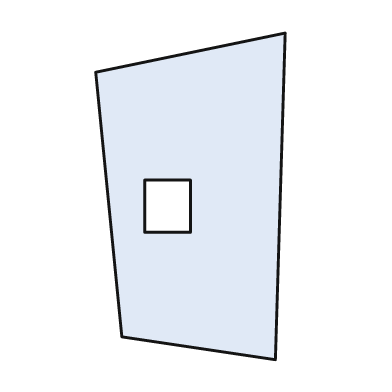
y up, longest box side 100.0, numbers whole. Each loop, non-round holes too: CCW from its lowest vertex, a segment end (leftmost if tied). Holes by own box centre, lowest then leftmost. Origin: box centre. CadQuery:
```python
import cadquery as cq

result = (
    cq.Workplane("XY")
    .moveTo(26.0, -50.0)
    .lineTo(29.0, 50.0)
    .lineTo(-29.0, 38.0)
    .lineTo(-21.0, -43.0)
    .close()
    .moveTo(-14.0, -11.0)
    .lineTo(0.0, -11.0)
    .lineTo(0.0, 5.0)
    .lineTo(-14.0, 5.0)
    .close()
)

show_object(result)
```